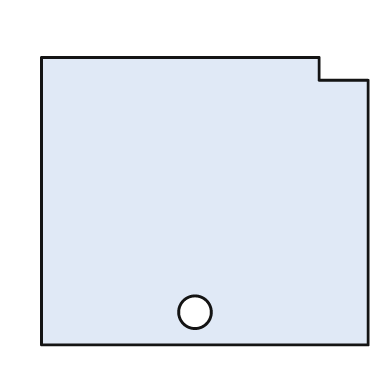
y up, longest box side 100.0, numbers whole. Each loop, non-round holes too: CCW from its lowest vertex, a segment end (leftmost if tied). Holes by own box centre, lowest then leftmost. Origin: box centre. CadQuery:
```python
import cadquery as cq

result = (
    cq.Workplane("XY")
    .moveTo(-50.0, -44.0)
    .lineTo(50.0, -44.0)
    .lineTo(50.0, 37.0)
    .lineTo(35.0, 37.0)
    .lineTo(35.0, 44.0)
    .lineTo(-50.0, 44.0)
    .close()
    .moveTo(-3.0, -34.0)
    .circle(5.0)
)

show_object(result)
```